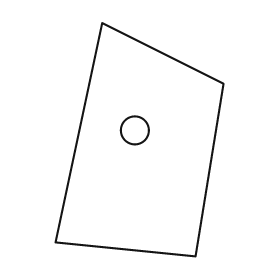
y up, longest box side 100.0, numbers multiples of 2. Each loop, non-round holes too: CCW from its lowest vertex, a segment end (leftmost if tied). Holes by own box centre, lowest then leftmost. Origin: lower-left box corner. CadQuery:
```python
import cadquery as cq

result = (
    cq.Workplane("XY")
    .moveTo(60.0, 0.0)
    .lineTo(72.0, 74.0)
    .lineTo(20.0, 100.0)
    .lineTo(0.0, 6.0)
    .close()
    .moveTo(34.0, 54.0)
    .circle(6.0)
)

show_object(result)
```